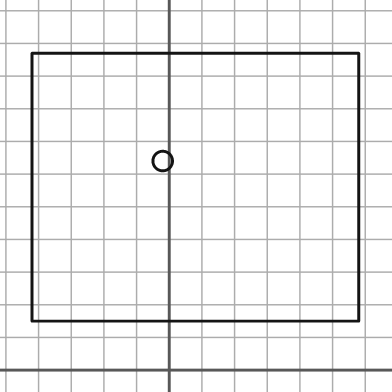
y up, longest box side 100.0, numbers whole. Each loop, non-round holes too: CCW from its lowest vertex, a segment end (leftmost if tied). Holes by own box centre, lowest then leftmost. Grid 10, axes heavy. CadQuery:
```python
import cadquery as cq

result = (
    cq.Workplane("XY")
    .moveTo(-42.0, 15.0)
    .lineTo(58.0, 15.0)
    .lineTo(58.0, 97.0)
    .lineTo(-42.0, 97.0)
    .close()
    .moveTo(-2.0, 64.0)
    .circle(3.0)
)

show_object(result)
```